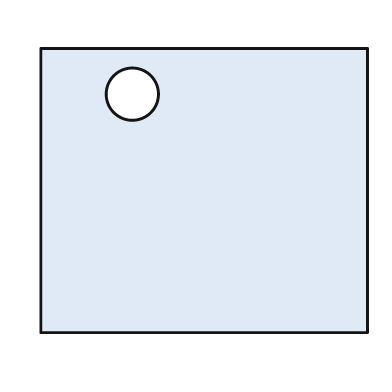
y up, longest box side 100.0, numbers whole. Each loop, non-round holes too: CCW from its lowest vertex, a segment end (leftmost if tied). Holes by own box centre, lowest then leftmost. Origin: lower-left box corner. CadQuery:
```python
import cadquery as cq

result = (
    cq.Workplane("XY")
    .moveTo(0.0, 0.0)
    .lineTo(100.0, 0.0)
    .lineTo(100.0, 87.0)
    .lineTo(0.0, 87.0)
    .close()
    .moveTo(28.0, 73.0)
    .circle(8.0)
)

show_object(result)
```